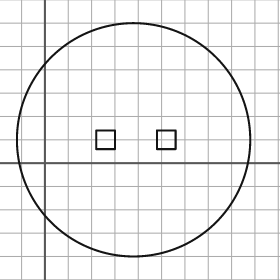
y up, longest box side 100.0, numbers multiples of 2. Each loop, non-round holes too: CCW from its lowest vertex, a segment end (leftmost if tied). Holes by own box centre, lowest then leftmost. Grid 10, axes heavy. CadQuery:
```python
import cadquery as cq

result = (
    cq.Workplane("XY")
    .moveTo(38.0, 10.0)
    .circle(50.0)
    .moveTo(22.0, 6.0)
    .lineTo(30.0, 6.0)
    .lineTo(30.0, 14.0)
    .lineTo(22.0, 14.0)
    .close()
    .moveTo(48.0, 6.0)
    .lineTo(56.0, 6.0)
    .lineTo(56.0, 14.0)
    .lineTo(48.0, 14.0)
    .close()
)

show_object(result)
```